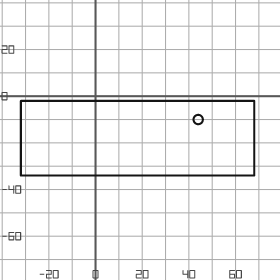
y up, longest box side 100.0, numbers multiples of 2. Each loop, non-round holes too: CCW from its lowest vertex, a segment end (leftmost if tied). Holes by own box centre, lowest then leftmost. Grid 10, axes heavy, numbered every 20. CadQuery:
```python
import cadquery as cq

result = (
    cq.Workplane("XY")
    .moveTo(-32.0, -34.0)
    .lineTo(68.0, -34.0)
    .lineTo(68.0, -2.0)
    .lineTo(-32.0, -2.0)
    .close()
    .moveTo(44.0, -10.0)
    .circle(2.0)
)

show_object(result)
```